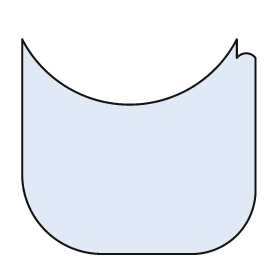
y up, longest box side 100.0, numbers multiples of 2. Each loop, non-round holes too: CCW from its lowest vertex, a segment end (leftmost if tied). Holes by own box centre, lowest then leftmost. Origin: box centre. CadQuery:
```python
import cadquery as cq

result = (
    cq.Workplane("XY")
    .moveTo(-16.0, -46.0)
    .lineTo(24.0, -46.0)
    .threePointArc((42.0, -38.0), (50.0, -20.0))
    .lineTo(50.0, 38.0)
    .threePointArc((46.0, 40.0), (42.0, 38.0))
    .lineTo(42.0, 46.0)
    .threePointArc((-4.0, 18.0), (-50.0, 46.0))
    .lineTo(-50.0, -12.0)
    .threePointArc((-40.0, -36.0), (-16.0, -46.0))
    .close()
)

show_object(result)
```